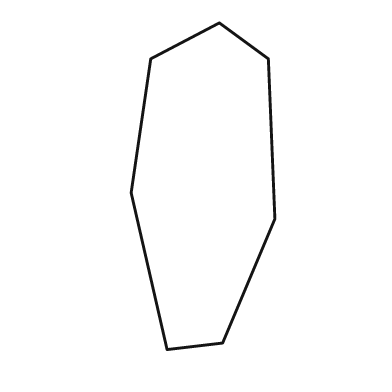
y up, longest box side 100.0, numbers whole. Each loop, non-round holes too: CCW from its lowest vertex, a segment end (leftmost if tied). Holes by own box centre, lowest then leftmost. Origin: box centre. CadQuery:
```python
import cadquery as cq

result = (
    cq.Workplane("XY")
    .moveTo(-11.0, -50.0)
    .lineTo(6.0, -48.0)
    .lineTo(22.0, -10.0)
    .lineTo(20.0, 39.0)
    .lineTo(5.0, 50.0)
    .lineTo(-16.0, 39.0)
    .lineTo(-22.0, -2.0)
    .close()
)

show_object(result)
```